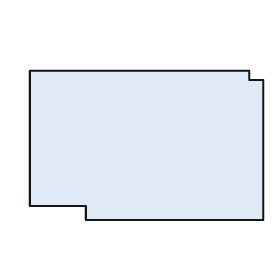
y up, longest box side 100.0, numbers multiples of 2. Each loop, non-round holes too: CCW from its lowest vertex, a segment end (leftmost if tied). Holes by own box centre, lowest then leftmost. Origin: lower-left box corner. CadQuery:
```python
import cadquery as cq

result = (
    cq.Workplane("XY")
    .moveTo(24.0, 0.0)
    .lineTo(100.0, 0.0)
    .lineTo(100.0, 60.0)
    .lineTo(94.0, 60.0)
    .lineTo(94.0, 64.0)
    .lineTo(0.0, 64.0)
    .lineTo(0.0, 6.0)
    .lineTo(24.0, 6.0)
    .close()
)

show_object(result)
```